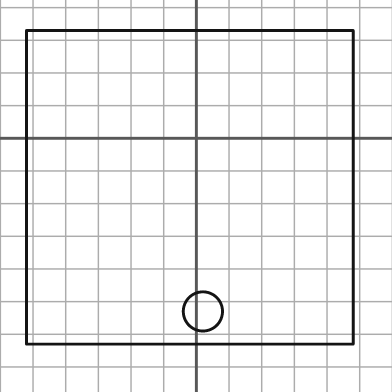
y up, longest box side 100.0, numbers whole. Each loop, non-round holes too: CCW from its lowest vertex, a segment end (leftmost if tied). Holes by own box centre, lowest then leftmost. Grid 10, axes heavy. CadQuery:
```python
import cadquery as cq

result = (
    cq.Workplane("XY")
    .moveTo(-52.0, -63.0)
    .lineTo(48.0, -63.0)
    .lineTo(48.0, 33.0)
    .lineTo(-52.0, 33.0)
    .close()
    .moveTo(2.0, -53.0)
    .circle(6.0)
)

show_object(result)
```